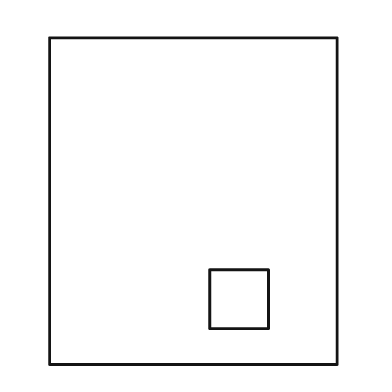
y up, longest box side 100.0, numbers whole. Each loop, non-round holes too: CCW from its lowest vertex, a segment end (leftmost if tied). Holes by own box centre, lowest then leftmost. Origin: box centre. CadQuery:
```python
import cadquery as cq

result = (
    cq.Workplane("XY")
    .moveTo(-44.0, -50.0)
    .lineTo(44.0, -50.0)
    .lineTo(44.0, 50.0)
    .lineTo(-44.0, 50.0)
    .close()
    .moveTo(5.0, -39.0)
    .lineTo(23.0, -39.0)
    .lineTo(23.0, -21.0)
    .lineTo(5.0, -21.0)
    .close()
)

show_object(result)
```